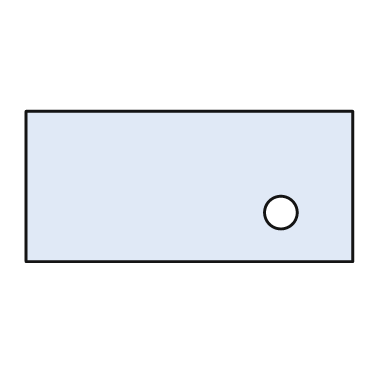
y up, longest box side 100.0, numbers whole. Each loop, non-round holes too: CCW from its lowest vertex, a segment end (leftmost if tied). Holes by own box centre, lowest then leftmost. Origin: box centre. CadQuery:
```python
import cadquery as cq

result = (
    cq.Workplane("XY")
    .moveTo(-50.0, -23.0)
    .lineTo(50.0, -23.0)
    .lineTo(50.0, 23.0)
    .lineTo(-50.0, 23.0)
    .close()
    .moveTo(28.0, -8.0)
    .circle(5.0)
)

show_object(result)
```